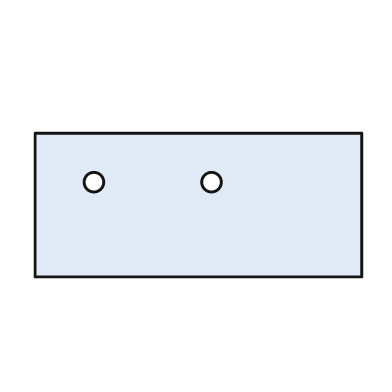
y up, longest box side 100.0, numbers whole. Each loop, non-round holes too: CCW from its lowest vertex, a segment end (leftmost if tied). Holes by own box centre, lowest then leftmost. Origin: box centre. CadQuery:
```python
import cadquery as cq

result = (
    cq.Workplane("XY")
    .moveTo(-50.0, -22.0)
    .lineTo(50.0, -22.0)
    .lineTo(50.0, 22.0)
    .lineTo(-50.0, 22.0)
    .close()
    .moveTo(-32.0, 7.0)
    .circle(3.0)
    .moveTo(4.0, 7.0)
    .circle(3.0)
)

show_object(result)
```